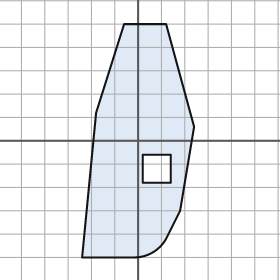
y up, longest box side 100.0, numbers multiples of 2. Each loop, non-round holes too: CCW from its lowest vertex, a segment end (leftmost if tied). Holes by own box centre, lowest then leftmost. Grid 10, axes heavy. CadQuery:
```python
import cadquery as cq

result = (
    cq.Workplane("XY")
    .moveTo(-24.0, -50.0)
    .lineTo(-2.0, -50.0)
    .threePointArc((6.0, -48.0), (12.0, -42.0))
    .lineTo(18.0, -30.0)
    .lineTo(24.0, 6.0)
    .lineTo(12.0, 50.0)
    .lineTo(-6.0, 50.0)
    .lineTo(-18.0, 12.0)
    .close()
    .moveTo(2.0, -18.0)
    .lineTo(14.0, -18.0)
    .lineTo(14.0, -6.0)
    .lineTo(2.0, -6.0)
    .close()
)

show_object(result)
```